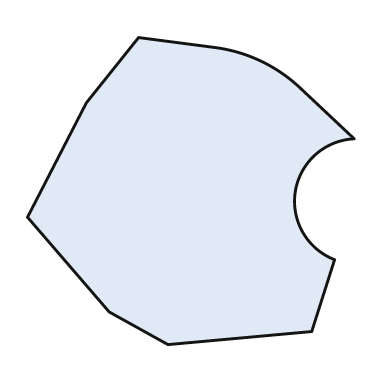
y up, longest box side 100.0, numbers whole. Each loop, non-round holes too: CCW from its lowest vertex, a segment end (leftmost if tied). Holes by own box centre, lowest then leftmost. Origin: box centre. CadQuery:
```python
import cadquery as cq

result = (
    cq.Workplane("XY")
    .moveTo(-7.0, -47.0)
    .lineTo(37.0, -43.0)
    .lineTo(44.0, -21.0)
    .threePointArc((32.0, 0.0), (50.0, 16.0))
    .lineTo(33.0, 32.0)
    .threePointArc((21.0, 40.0), (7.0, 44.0))
    .lineTo(-16.0, 47.0)
    .lineTo(-32.0, 27.0)
    .lineTo(-50.0, -8.0)
    .lineTo(-25.0, -37.0)
    .close()
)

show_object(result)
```